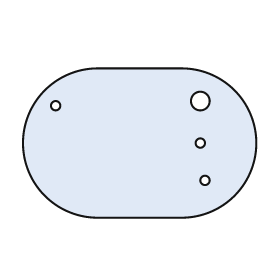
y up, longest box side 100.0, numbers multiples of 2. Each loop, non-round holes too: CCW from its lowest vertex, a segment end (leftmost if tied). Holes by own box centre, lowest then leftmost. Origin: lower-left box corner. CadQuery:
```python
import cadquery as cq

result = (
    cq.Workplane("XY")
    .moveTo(32.0, 0.0)
    .lineTo(68.0, 0.0)
    .threePointArc((100.0, 32.0), (68.0, 64.0))
    .lineTo(32.0, 64.0)
    .threePointArc((0.0, 32.0), (32.0, 0.0))
    .close()
    .moveTo(78.0, 16.0)
    .circle(2.0)
    .moveTo(76.0, 32.0)
    .circle(2.0)
    .moveTo(14.0, 48.0)
    .circle(2.0)
    .moveTo(76.0, 50.0)
    .circle(4.0)
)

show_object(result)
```